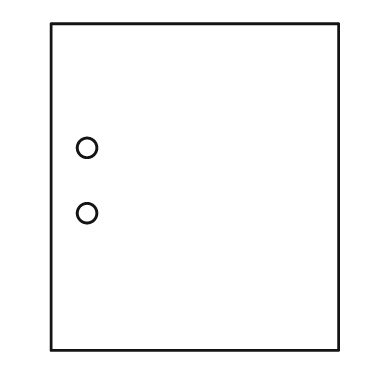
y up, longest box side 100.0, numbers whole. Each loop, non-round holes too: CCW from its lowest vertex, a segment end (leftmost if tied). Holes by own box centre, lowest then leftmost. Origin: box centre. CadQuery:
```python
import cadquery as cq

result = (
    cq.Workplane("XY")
    .moveTo(-44.0, -50.0)
    .lineTo(44.0, -50.0)
    .lineTo(44.0, 50.0)
    .lineTo(-44.0, 50.0)
    .close()
    .moveTo(-33.0, -8.0)
    .circle(3.0)
    .moveTo(-33.0, 12.0)
    .circle(3.0)
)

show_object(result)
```